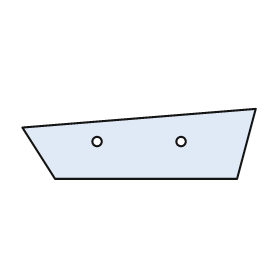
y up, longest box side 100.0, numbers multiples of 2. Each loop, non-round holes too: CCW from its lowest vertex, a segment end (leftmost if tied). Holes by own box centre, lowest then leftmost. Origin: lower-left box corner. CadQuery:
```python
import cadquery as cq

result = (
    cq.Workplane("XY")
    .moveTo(14.0, 0.0)
    .lineTo(92.0, 0.0)
    .lineTo(100.0, 30.0)
    .lineTo(0.0, 22.0)
    .close()
    .moveTo(32.0, 16.0)
    .circle(2.0)
    .moveTo(68.0, 16.0)
    .circle(2.0)
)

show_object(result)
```